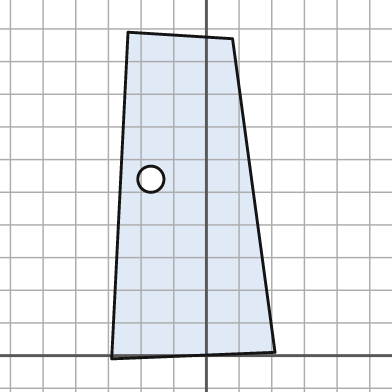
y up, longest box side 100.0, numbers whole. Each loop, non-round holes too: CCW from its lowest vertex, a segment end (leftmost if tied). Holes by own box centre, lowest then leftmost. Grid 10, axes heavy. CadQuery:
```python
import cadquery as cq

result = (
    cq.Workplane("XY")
    .moveTo(-29.0, -1.0)
    .lineTo(21.0, 1.0)
    .lineTo(8.0, 97.0)
    .lineTo(-24.0, 99.0)
    .close()
    .moveTo(-17.0, 54.0)
    .circle(4.0)
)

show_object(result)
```